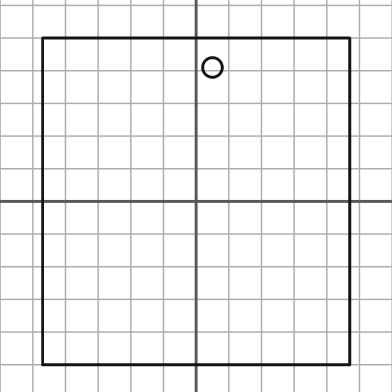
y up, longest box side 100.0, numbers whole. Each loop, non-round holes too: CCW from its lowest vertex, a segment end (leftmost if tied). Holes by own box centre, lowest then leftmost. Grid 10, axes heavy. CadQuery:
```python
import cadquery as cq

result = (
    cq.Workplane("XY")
    .moveTo(-47.0, -50.0)
    .lineTo(47.0, -50.0)
    .lineTo(47.0, 50.0)
    .lineTo(-47.0, 50.0)
    .close()
    .moveTo(5.0, 41.0)
    .circle(3.0)
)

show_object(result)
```